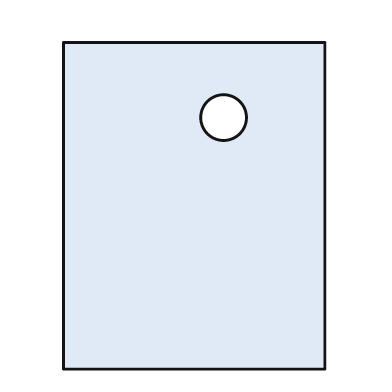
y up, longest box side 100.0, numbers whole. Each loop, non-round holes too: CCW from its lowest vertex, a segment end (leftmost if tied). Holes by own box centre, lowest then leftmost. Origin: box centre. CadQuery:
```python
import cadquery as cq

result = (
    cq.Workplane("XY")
    .moveTo(-40.0, -50.0)
    .lineTo(40.0, -50.0)
    .lineTo(40.0, 50.0)
    .lineTo(-40.0, 50.0)
    .close()
    .moveTo(9.0, 27.0)
    .circle(7.0)
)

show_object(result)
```